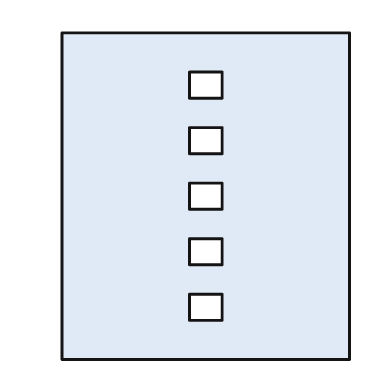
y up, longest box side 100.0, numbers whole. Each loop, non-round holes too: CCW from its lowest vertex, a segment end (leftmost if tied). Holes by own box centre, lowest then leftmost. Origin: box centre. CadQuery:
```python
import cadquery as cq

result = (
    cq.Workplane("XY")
    .moveTo(-44.0, -50.0)
    .lineTo(44.0, -50.0)
    .lineTo(44.0, 50.0)
    .lineTo(-44.0, 50.0)
    .close()
    .moveTo(-5.0, -38.0)
    .lineTo(5.0, -38.0)
    .lineTo(5.0, -30.0)
    .lineTo(-5.0, -30.0)
    .close()
    .moveTo(-5.0, -21.0)
    .lineTo(5.0, -21.0)
    .lineTo(5.0, -13.0)
    .lineTo(-5.0, -13.0)
    .close()
    .moveTo(-5.0, -4.0)
    .lineTo(5.0, -4.0)
    .lineTo(5.0, 4.0)
    .lineTo(-5.0, 4.0)
    .close()
    .moveTo(-5.0, 13.0)
    .lineTo(5.0, 13.0)
    .lineTo(5.0, 21.0)
    .lineTo(-5.0, 21.0)
    .close()
    .moveTo(-5.0, 30.0)
    .lineTo(5.0, 30.0)
    .lineTo(5.0, 38.0)
    .lineTo(-5.0, 38.0)
    .close()
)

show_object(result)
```